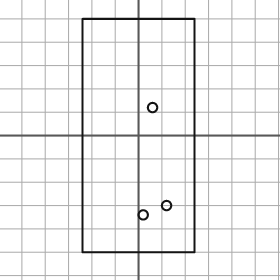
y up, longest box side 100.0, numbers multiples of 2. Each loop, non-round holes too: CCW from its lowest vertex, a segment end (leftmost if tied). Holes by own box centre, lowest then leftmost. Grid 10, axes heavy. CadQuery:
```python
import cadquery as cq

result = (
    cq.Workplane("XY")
    .moveTo(-24.0, -50.0)
    .lineTo(24.0, -50.0)
    .lineTo(24.0, 50.0)
    .lineTo(-24.0, 50.0)
    .close()
    .moveTo(2.0, -34.0)
    .circle(2.0)
    .moveTo(12.0, -30.0)
    .circle(2.0)
    .moveTo(6.0, 12.0)
    .circle(2.0)
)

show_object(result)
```